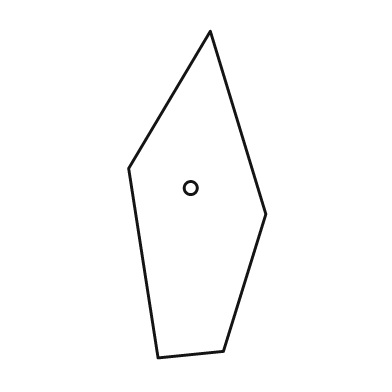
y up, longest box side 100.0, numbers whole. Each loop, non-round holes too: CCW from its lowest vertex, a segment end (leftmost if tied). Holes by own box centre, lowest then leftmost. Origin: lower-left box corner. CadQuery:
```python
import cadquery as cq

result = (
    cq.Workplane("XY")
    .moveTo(9.0, 0.0)
    .lineTo(29.0, 2.0)
    .lineTo(42.0, 44.0)
    .lineTo(25.0, 100.0)
    .lineTo(0.0, 58.0)
    .close()
    .moveTo(19.0, 52.0)
    .circle(2.0)
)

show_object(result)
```